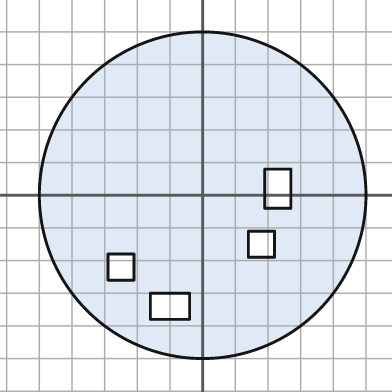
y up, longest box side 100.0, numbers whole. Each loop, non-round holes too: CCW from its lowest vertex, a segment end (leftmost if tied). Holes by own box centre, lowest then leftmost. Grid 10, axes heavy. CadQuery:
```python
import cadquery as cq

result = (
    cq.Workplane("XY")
    .moveTo(0.0, 0.0)
    .circle(50.0)
    .moveTo(-16.0, -38.0)
    .lineTo(-4.0, -38.0)
    .lineTo(-4.0, -30.0)
    .lineTo(-16.0, -30.0)
    .close()
    .moveTo(-29.0, -26.0)
    .lineTo(-21.0, -26.0)
    .lineTo(-21.0, -18.0)
    .lineTo(-29.0, -18.0)
    .close()
    .moveTo(14.0, -19.0)
    .lineTo(22.0, -19.0)
    .lineTo(22.0, -11.0)
    .lineTo(14.0, -11.0)
    .close()
    .moveTo(19.0, -4.0)
    .lineTo(27.0, -4.0)
    .lineTo(27.0, 8.0)
    .lineTo(19.0, 8.0)
    .close()
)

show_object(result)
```